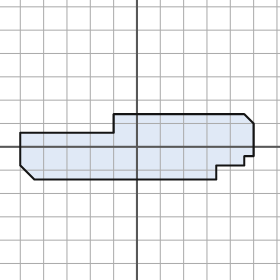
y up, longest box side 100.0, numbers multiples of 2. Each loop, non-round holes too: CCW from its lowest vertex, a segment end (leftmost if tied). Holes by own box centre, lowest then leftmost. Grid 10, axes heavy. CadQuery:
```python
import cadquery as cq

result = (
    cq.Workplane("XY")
    .moveTo(-44.0, -14.0)
    .lineTo(34.0, -14.0)
    .lineTo(34.0, -8.0)
    .lineTo(46.0, -8.0)
    .lineTo(46.0, -4.0)
    .lineTo(50.0, -4.0)
    .lineTo(50.0, 10.0)
    .lineTo(46.0, 14.0)
    .lineTo(-10.0, 14.0)
    .lineTo(-10.0, 6.0)
    .lineTo(-50.0, 6.0)
    .lineTo(-50.0, -8.0)
    .close()
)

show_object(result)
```